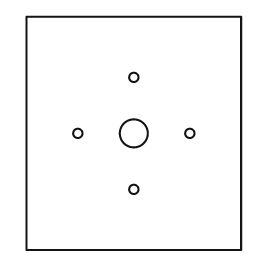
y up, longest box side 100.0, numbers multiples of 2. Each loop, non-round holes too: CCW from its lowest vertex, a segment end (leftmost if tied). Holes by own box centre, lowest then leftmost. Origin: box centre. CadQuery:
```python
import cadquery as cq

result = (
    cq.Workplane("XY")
    .moveTo(-46.0, -50.0)
    .lineTo(46.0, -50.0)
    .lineTo(46.0, 50.0)
    .lineTo(-46.0, 50.0)
    .close()
    .moveTo(0.0, -24.0)
    .circle(2.0)
    .moveTo(-24.0, 0.0)
    .circle(2.0)
    .moveTo(0.0, 0.0)
    .circle(6.0)
    .moveTo(24.0, 0.0)
    .circle(2.0)
    .moveTo(0.0, 24.0)
    .circle(2.0)
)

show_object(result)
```